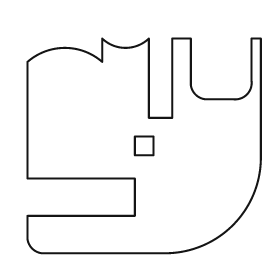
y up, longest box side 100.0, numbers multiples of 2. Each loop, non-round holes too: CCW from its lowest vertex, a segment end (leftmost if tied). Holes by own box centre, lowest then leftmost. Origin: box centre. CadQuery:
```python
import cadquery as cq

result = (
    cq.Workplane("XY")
    .moveTo(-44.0, -46.0)
    .lineTo(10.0, -46.0)
    .threePointArc((38.0, -34.0), (50.0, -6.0))
    .lineTo(50.0, 46.0)
    .lineTo(46.0, 46.0)
    .lineTo(46.0, 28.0)
    .threePointArc((44.0, 22.0), (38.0, 20.0))
    .lineTo(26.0, 20.0)
    .threePointArc((22.0, 22.0), (20.0, 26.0))
    .lineTo(20.0, 46.0)
    .lineTo(12.0, 46.0)
    .lineTo(12.0, 12.0)
    .lineTo(2.0, 12.0)
    .lineTo(2.0, 46.0)
    .threePointArc((-8.0, 42.0), (-18.0, 46.0))
    .lineTo(-18.0, 36.0)
    .threePointArc((-34.0, 42.0), (-50.0, 36.0))
    .lineTo(-50.0, -14.0)
    .lineTo(-4.0, -14.0)
    .lineTo(-4.0, -30.0)
    .lineTo(-50.0, -30.0)
    .lineTo(-50.0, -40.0)
    .threePointArc((-48.0, -44.0), (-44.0, -46.0))
    .close()
    .moveTo(-4.0, -4.0)
    .lineTo(4.0, -4.0)
    .lineTo(4.0, 4.0)
    .lineTo(-4.0, 4.0)
    .close()
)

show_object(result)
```